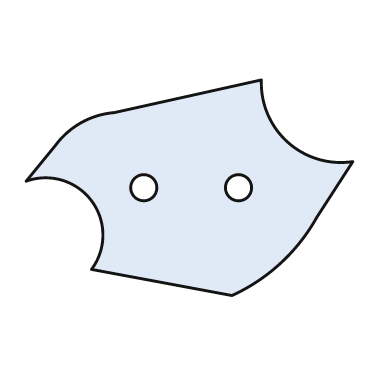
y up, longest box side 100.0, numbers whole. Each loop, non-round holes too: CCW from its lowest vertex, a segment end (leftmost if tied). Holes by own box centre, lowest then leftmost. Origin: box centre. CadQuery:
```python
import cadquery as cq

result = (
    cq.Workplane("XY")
    .moveTo(13.0, -33.0)
    .threePointArc((28.0, -23.0), (39.0, -9.0))
    .lineTo(50.0, 8.0)
    .threePointArc((30.0, 14.0), (22.0, 33.0))
    .lineTo(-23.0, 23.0)
    .threePointArc((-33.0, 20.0), (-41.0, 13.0))
    .lineTo(-50.0, 2.0)
    .threePointArc((-30.0, -4.0), (-30.0, -25.0))
    .close()
    .moveTo(-14.0, 0.0)
    .circle(4.0)
    .moveTo(15.0, 0.0)
    .circle(4.0)
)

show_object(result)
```